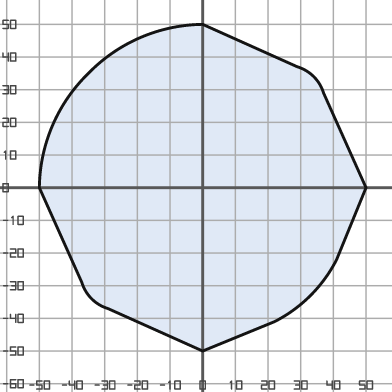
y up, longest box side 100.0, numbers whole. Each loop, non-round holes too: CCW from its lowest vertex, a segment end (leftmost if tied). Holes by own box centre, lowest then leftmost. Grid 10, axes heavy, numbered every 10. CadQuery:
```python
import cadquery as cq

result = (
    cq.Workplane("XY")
    .moveTo(0.0, -50.0)
    .lineTo(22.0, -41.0)
    .threePointArc((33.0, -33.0), (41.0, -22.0))
    .lineTo(50.0, 0.0)
    .lineTo(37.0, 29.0)
    .threePointArc((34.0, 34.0), (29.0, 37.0))
    .lineTo(0.0, 50.0)
    .threePointArc((-19.0, 46.0), (-35.0, 35.0))
    .threePointArc((-46.0, 19.0), (-50.0, 0.0))
    .lineTo(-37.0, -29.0)
    .threePointArc((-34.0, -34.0), (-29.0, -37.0))
    .close()
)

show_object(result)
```